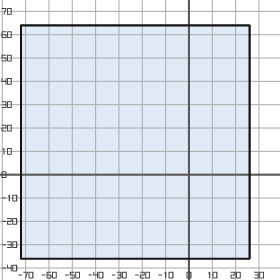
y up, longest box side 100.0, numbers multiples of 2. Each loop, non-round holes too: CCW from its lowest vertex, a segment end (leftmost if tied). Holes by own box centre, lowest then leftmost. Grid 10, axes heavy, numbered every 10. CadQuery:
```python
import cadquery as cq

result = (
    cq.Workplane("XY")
    .moveTo(-72.0, -36.0)
    .lineTo(26.0, -36.0)
    .lineTo(26.0, 64.0)
    .lineTo(-72.0, 64.0)
    .close()
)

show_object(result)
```